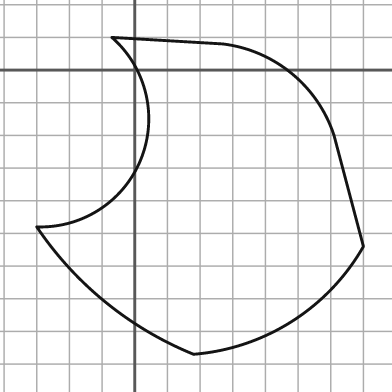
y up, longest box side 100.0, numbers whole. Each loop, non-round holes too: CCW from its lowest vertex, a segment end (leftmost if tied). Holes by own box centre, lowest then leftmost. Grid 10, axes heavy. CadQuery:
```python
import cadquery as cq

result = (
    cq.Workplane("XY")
    .moveTo(18.0, -87.0)
    .threePointArc((48.0, -77.0), (70.0, -54.0))
    .lineTo(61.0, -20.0)
    .threePointArc((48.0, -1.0), (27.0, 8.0))
    .lineTo(-7.0, 10.0)
    .threePointArc((2.0, -27.0), (-30.0, -48.0))
    .threePointArc((-9.0, -71.0), (18.0, -87.0))
    .close()
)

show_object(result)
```